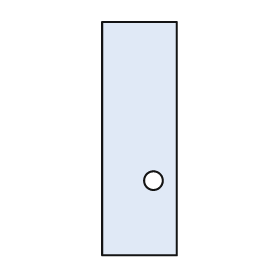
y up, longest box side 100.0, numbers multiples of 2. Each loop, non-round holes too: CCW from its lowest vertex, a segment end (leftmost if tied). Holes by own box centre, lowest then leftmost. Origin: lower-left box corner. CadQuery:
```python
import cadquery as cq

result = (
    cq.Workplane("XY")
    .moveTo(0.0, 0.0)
    .lineTo(32.0, 0.0)
    .lineTo(32.0, 100.0)
    .lineTo(0.0, 100.0)
    .close()
    .moveTo(22.0, 32.0)
    .circle(4.0)
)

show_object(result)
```